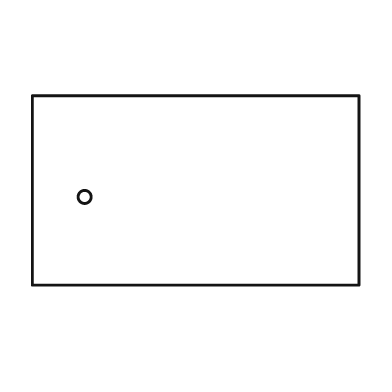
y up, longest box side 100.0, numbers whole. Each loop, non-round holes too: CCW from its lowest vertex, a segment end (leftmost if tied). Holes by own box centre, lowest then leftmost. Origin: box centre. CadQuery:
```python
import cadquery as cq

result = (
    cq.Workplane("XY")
    .moveTo(-50.0, -29.0)
    .lineTo(50.0, -29.0)
    .lineTo(50.0, 29.0)
    .lineTo(-50.0, 29.0)
    .close()
    .moveTo(-34.0, -2.0)
    .circle(2.0)
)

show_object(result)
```